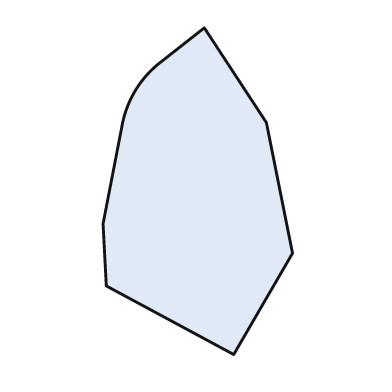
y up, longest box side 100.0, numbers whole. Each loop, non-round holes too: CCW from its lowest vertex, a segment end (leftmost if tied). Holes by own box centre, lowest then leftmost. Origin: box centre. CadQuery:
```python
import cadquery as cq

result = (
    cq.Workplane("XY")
    .moveTo(11.0, -50.0)
    .lineTo(29.0, -19.0)
    .lineTo(21.0, 21.0)
    .lineTo(2.0, 50.0)
    .lineTo(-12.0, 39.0)
    .threePointArc((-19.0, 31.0), (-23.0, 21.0))
    .lineTo(-29.0, -10.0)
    .lineTo(-28.0, -29.0)
    .close()
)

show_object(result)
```